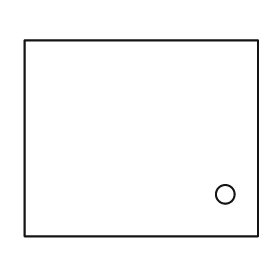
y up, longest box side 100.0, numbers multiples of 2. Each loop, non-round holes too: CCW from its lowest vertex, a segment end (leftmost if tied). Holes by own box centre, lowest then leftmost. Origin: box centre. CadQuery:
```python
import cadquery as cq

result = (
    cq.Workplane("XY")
    .moveTo(-50.0, -42.0)
    .lineTo(50.0, -42.0)
    .lineTo(50.0, 42.0)
    .lineTo(-50.0, 42.0)
    .close()
    .moveTo(36.0, -24.0)
    .circle(4.0)
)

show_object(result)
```